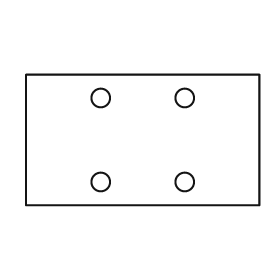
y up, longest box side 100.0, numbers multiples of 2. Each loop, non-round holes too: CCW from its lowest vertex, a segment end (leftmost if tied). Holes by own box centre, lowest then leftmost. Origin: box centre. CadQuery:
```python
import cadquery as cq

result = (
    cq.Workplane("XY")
    .moveTo(-50.0, -28.0)
    .lineTo(50.0, -28.0)
    .lineTo(50.0, 28.0)
    .lineTo(-50.0, 28.0)
    .close()
    .moveTo(-18.0, -18.0)
    .circle(4.0)
    .moveTo(18.0, -18.0)
    .circle(4.0)
    .moveTo(-18.0, 18.0)
    .circle(4.0)
    .moveTo(18.0, 18.0)
    .circle(4.0)
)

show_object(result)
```